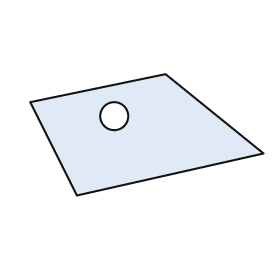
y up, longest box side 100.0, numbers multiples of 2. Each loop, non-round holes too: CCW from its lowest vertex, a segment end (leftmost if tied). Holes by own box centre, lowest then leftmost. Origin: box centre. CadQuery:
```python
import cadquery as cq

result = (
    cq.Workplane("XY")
    .moveTo(-30.0, -26.0)
    .lineTo(50.0, -8.0)
    .lineTo(8.0, 26.0)
    .lineTo(-50.0, 14.0)
    .close()
    .moveTo(-14.0, 8.0)
    .circle(6.0)
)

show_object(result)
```